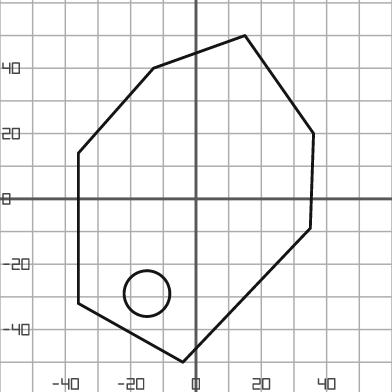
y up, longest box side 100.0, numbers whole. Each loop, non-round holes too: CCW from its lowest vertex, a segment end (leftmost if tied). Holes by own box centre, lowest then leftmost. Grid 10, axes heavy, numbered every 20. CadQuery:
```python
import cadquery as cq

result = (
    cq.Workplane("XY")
    .moveTo(-4.0, -50.0)
    .lineTo(35.0, -9.0)
    .lineTo(36.0, 20.0)
    .lineTo(15.0, 50.0)
    .lineTo(-13.0, 40.0)
    .lineTo(-36.0, 14.0)
    .lineTo(-36.0, -32.0)
    .close()
    .moveTo(-15.0, -29.0)
    .circle(7.0)
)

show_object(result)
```